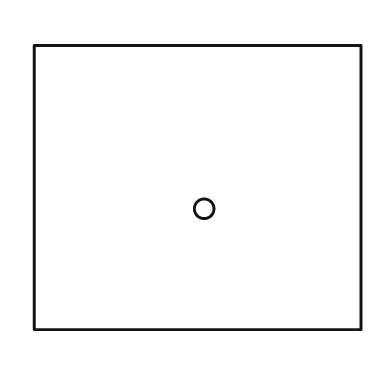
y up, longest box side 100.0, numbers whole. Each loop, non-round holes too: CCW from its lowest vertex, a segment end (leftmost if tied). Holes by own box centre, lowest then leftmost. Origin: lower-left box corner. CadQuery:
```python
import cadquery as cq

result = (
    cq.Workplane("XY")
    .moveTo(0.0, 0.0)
    .lineTo(100.0, 0.0)
    .lineTo(100.0, 87.0)
    .lineTo(0.0, 87.0)
    .close()
    .moveTo(52.0, 37.0)
    .circle(3.0)
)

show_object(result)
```